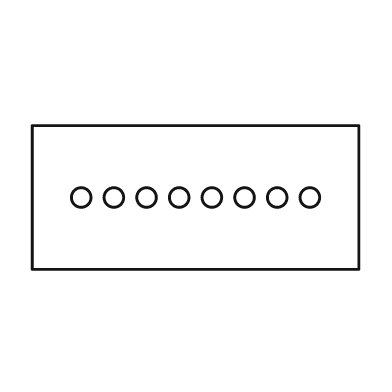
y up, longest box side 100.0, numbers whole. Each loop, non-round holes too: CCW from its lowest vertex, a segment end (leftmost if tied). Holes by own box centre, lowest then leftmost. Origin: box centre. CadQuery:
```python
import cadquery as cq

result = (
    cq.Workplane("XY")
    .moveTo(-50.0, -22.0)
    .lineTo(50.0, -22.0)
    .lineTo(50.0, 22.0)
    .lineTo(-50.0, 22.0)
    .close()
    .moveTo(-35.0, 0.0)
    .circle(3.0)
    .moveTo(-25.0, 0.0)
    .circle(3.0)
    .moveTo(-15.0, 0.0)
    .circle(3.0)
    .moveTo(-5.0, 0.0)
    .circle(3.0)
    .moveTo(5.0, 0.0)
    .circle(3.0)
    .moveTo(15.0, 0.0)
    .circle(3.0)
    .moveTo(25.0, 0.0)
    .circle(3.0)
    .moveTo(35.0, 0.0)
    .circle(3.0)
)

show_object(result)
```